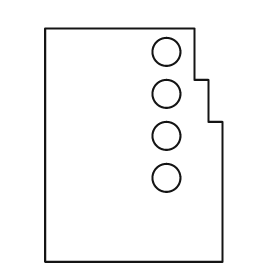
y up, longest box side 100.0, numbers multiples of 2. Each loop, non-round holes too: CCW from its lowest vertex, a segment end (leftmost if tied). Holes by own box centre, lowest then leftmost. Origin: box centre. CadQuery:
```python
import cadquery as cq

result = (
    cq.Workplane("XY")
    .moveTo(-38.0, -50.0)
    .lineTo(38.0, -50.0)
    .lineTo(38.0, 10.0)
    .lineTo(32.0, 10.0)
    .lineTo(32.0, 28.0)
    .lineTo(26.0, 28.0)
    .lineTo(26.0, 50.0)
    .lineTo(-38.0, 50.0)
    .close()
    .moveTo(14.0, -14.0)
    .circle(6.0)
    .moveTo(14.0, 4.0)
    .circle(6.0)
    .moveTo(14.0, 22.0)
    .circle(6.0)
    .moveTo(14.0, 40.0)
    .circle(6.0)
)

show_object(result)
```